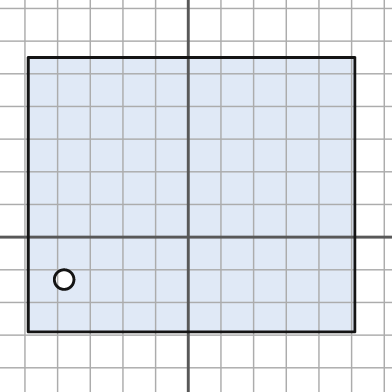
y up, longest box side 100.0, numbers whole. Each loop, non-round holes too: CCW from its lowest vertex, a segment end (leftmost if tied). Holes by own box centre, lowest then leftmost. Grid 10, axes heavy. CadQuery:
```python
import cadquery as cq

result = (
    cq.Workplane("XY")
    .moveTo(-49.0, -29.0)
    .lineTo(51.0, -29.0)
    .lineTo(51.0, 55.0)
    .lineTo(-49.0, 55.0)
    .close()
    .moveTo(-38.0, -13.0)
    .circle(3.0)
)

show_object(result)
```